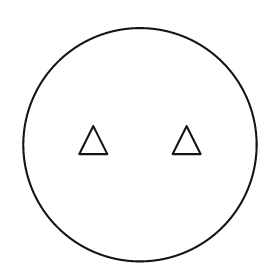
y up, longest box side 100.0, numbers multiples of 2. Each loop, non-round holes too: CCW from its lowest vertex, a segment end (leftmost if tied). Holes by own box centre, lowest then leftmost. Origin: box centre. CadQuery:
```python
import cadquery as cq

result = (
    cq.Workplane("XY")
    .moveTo(0.0, 0.0)
    .circle(50.0)
    .moveTo(-26.0, -4.0)
    .lineTo(-14.0, -4.0)
    .lineTo(-20.0, 8.0)
    .close()
    .moveTo(14.0, -4.0)
    .lineTo(26.0, -4.0)
    .lineTo(20.0, 8.0)
    .close()
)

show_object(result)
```